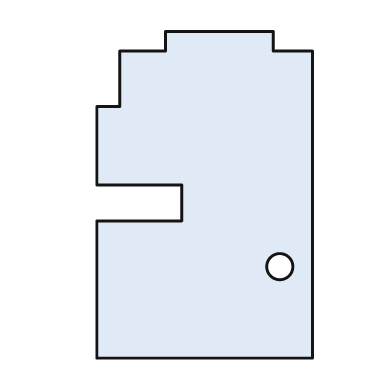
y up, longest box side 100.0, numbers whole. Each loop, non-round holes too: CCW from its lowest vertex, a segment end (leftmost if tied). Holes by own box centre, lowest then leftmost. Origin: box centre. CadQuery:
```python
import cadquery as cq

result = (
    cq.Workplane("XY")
    .moveTo(-33.0, -50.0)
    .lineTo(33.0, -50.0)
    .lineTo(33.0, 44.0)
    .lineTo(21.0, 44.0)
    .lineTo(21.0, 50.0)
    .lineTo(-12.0, 50.0)
    .lineTo(-12.0, 44.0)
    .lineTo(-26.0, 44.0)
    .lineTo(-26.0, 27.0)
    .lineTo(-33.0, 27.0)
    .lineTo(-33.0, 3.0)
    .lineTo(-7.0, 3.0)
    .lineTo(-7.0, -8.0)
    .lineTo(-33.0, -8.0)
    .close()
    .moveTo(23.0, -22.0)
    .circle(4.0)
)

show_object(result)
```